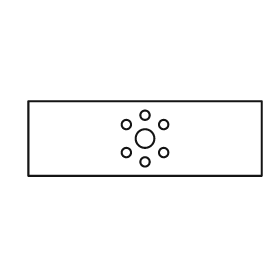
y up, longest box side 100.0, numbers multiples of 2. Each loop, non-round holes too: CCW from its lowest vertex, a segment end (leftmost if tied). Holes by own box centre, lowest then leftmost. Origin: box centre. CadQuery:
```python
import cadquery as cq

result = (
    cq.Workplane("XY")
    .moveTo(-50.0, -16.0)
    .lineTo(50.0, -16.0)
    .lineTo(50.0, 16.0)
    .lineTo(-50.0, 16.0)
    .close()
    .moveTo(0.0, -10.0)
    .circle(2.0)
    .moveTo(-8.0, -6.0)
    .circle(2.0)
    .moveTo(8.0, -6.0)
    .circle(2.0)
    .moveTo(0.0, 0.0)
    .circle(4.0)
    .moveTo(-8.0, 6.0)
    .circle(2.0)
    .moveTo(8.0, 6.0)
    .circle(2.0)
    .moveTo(0.0, 10.0)
    .circle(2.0)
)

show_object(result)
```